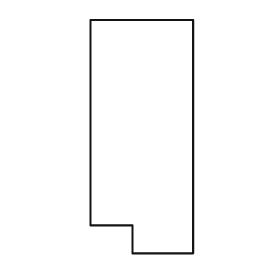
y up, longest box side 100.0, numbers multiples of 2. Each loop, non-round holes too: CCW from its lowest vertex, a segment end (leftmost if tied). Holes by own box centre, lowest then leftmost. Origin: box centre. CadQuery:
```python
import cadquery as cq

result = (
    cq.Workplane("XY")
    .moveTo(-4.0, -50.0)
    .lineTo(22.0, -50.0)
    .lineTo(22.0, 50.0)
    .lineTo(-22.0, 50.0)
    .lineTo(-22.0, -38.0)
    .lineTo(-4.0, -38.0)
    .close()
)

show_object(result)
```